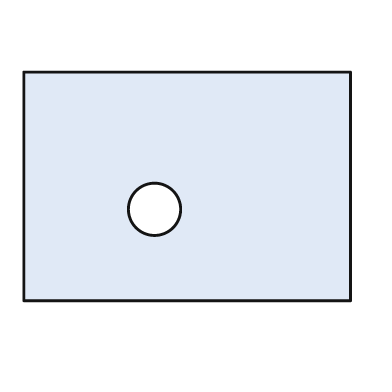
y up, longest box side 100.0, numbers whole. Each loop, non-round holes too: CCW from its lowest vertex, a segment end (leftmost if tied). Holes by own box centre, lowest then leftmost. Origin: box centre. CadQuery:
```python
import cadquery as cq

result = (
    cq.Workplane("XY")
    .moveTo(-50.0, -35.0)
    .lineTo(50.0, -35.0)
    .lineTo(50.0, 35.0)
    .lineTo(-50.0, 35.0)
    .close()
    .moveTo(-10.0, -7.0)
    .circle(8.0)
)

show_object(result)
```